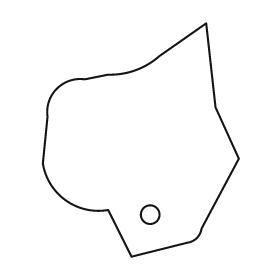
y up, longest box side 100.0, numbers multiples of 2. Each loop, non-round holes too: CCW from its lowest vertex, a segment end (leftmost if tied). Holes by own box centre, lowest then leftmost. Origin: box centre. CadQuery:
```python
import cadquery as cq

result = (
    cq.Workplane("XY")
    .moveTo(-4.0, -50.0)
    .lineTo(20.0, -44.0)
    .threePointArc((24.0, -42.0), (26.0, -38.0))
    .lineTo(42.0, -8.0)
    .lineTo(32.0, 14.0)
    .lineTo(28.0, 50.0)
    .lineTo(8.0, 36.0)
    .threePointArc((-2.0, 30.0), (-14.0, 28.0))
    .lineTo(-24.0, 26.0)
    .threePointArc((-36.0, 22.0), (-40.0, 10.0))
    .lineTo(-42.0, -10.0)
    .threePointArc((-32.0, -26.0), (-14.0, -30.0))
    .close()
    .moveTo(4.0, -32.0)
    .circle(4.0)
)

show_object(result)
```